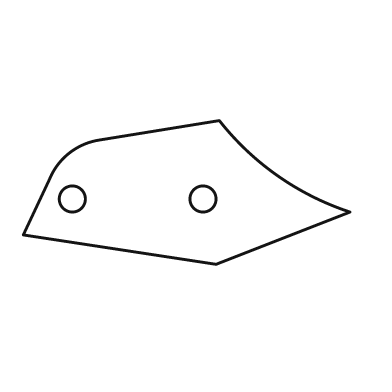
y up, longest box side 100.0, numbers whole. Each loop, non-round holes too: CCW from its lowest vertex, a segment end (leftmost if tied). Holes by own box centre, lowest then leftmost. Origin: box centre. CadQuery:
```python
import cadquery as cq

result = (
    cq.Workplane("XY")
    .moveTo(9.0, -22.0)
    .lineTo(50.0, -6.0)
    .threePointArc((28.0, 5.0), (10.0, 22.0))
    .lineTo(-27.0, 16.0)
    .threePointArc((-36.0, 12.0), (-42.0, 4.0))
    .lineTo(-50.0, -13.0)
    .close()
    .moveTo(-35.0, -2.0)
    .circle(4.0)
    .moveTo(5.0, -2.0)
    .circle(4.0)
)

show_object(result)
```